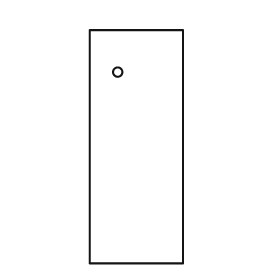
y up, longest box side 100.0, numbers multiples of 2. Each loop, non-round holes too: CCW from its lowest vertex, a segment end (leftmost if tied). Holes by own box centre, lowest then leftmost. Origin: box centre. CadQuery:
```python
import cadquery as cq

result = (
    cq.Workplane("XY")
    .moveTo(-20.0, -50.0)
    .lineTo(20.0, -50.0)
    .lineTo(20.0, 50.0)
    .lineTo(-20.0, 50.0)
    .close()
    .moveTo(-8.0, 32.0)
    .circle(2.0)
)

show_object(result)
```